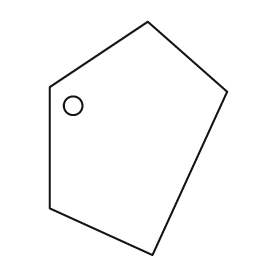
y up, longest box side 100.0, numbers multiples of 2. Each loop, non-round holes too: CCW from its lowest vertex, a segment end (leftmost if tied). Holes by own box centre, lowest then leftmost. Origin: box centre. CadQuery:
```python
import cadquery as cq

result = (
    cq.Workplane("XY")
    .moveTo(6.0, -50.0)
    .lineTo(38.0, 20.0)
    .lineTo(4.0, 50.0)
    .lineTo(-38.0, 22.0)
    .lineTo(-38.0, -30.0)
    .close()
    .moveTo(-28.0, 14.0)
    .circle(4.0)
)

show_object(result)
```